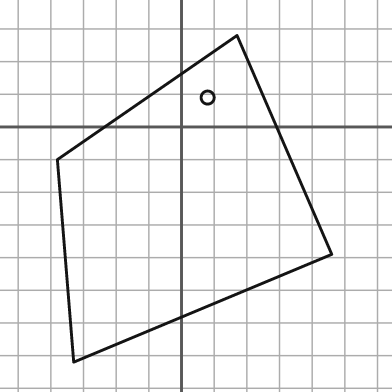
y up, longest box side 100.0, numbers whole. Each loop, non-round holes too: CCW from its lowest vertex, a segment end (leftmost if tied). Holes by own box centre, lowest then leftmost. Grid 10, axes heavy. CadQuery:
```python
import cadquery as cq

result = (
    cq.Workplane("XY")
    .moveTo(-33.0, -72.0)
    .lineTo(46.0, -39.0)
    .lineTo(17.0, 28.0)
    .lineTo(-38.0, -10.0)
    .close()
    .moveTo(8.0, 9.0)
    .circle(2.0)
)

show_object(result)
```